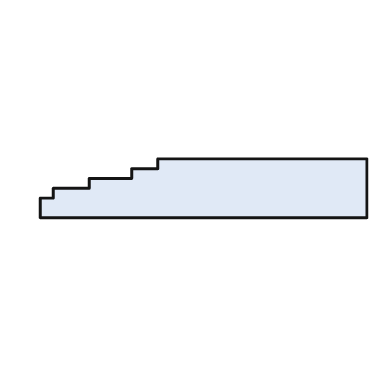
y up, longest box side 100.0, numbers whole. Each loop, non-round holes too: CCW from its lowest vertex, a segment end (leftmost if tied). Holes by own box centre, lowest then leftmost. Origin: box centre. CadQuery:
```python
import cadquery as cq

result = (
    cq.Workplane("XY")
    .moveTo(-50.0, -9.0)
    .lineTo(50.0, -9.0)
    .lineTo(50.0, 9.0)
    .lineTo(-14.0, 9.0)
    .lineTo(-14.0, 6.0)
    .lineTo(-22.0, 6.0)
    .lineTo(-22.0, 3.0)
    .lineTo(-35.0, 3.0)
    .lineTo(-35.0, 0.0)
    .lineTo(-46.0, 0.0)
    .lineTo(-46.0, -3.0)
    .lineTo(-50.0, -3.0)
    .close()
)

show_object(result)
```